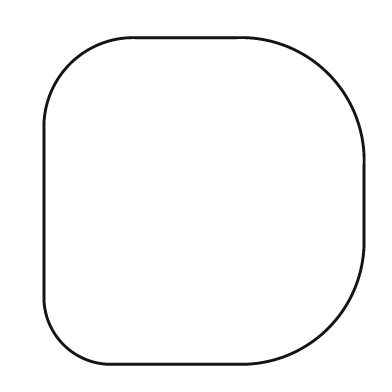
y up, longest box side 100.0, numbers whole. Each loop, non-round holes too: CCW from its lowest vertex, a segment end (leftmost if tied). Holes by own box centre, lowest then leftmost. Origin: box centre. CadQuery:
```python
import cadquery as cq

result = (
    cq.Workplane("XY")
    .moveTo(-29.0, -50.0)
    .lineTo(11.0, -50.0)
    .threePointArc((38.0, -39.0), (49.0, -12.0))
    .lineTo(49.0, 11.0)
    .threePointArc((38.0, 39.0), (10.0, 50.0))
    .lineTo(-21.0, 50.0)
    .threePointArc((-41.0, 42.0), (-49.0, 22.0))
    .lineTo(-49.0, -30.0)
    .threePointArc((-43.0, -44.0), (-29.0, -50.0))
    .close()
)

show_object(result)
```